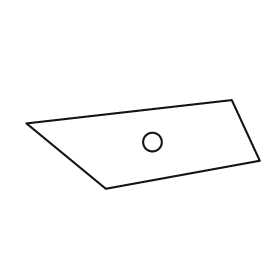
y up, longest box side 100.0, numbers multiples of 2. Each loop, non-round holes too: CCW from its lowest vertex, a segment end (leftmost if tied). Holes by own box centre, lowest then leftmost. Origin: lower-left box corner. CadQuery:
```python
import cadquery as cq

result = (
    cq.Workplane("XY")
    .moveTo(34.0, 0.0)
    .lineTo(100.0, 12.0)
    .lineTo(88.0, 38.0)
    .lineTo(0.0, 28.0)
    .close()
    .moveTo(54.0, 20.0)
    .circle(4.0)
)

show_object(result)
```